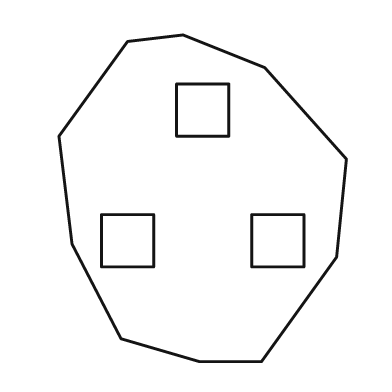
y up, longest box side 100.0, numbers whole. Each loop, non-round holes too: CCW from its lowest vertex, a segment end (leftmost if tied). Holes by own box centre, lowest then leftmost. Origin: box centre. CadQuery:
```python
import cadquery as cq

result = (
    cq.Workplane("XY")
    .moveTo(-1.0, -50.0)
    .lineTo(18.0, -50.0)
    .lineTo(41.0, -18.0)
    .lineTo(44.0, 12.0)
    .lineTo(19.0, 40.0)
    .lineTo(-6.0, 50.0)
    .lineTo(-23.0, 48.0)
    .lineTo(-44.0, 19.0)
    .lineTo(-40.0, -14.0)
    .lineTo(-25.0, -43.0)
    .close()
    .moveTo(-31.0, -21.0)
    .lineTo(-15.0, -21.0)
    .lineTo(-15.0, -5.0)
    .lineTo(-31.0, -5.0)
    .close()
    .moveTo(15.0, -21.0)
    .lineTo(31.0, -21.0)
    .lineTo(31.0, -5.0)
    .lineTo(15.0, -5.0)
    .close()
    .moveTo(-8.0, 19.0)
    .lineTo(8.0, 19.0)
    .lineTo(8.0, 35.0)
    .lineTo(-8.0, 35.0)
    .close()
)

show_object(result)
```